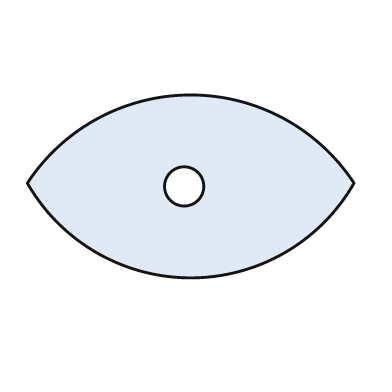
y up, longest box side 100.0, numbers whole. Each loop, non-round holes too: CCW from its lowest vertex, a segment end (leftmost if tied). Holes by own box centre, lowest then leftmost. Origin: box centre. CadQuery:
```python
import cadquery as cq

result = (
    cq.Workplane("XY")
    .moveTo(-50.0, 1.0)
    .threePointArc((0.0, -28.0), (50.0, 1.0))
    .threePointArc((0.0, 28.0), (-50.0, 1.0))
    .close()
    .moveTo(-2.0, 0.0)
    .circle(6.0)
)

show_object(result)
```